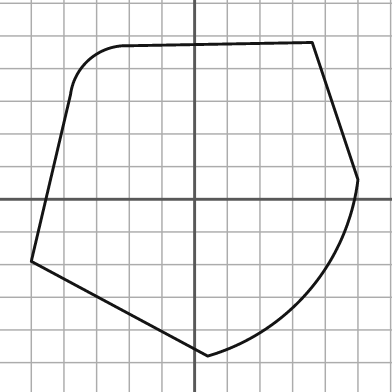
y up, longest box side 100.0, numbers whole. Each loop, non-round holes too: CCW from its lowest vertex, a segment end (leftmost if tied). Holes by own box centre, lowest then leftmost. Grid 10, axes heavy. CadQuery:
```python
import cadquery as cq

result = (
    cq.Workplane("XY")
    .moveTo(4.0, -48.0)
    .threePointArc((35.0, -28.0), (50.0, 6.0))
    .lineTo(36.0, 48.0)
    .lineTo(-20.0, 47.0)
    .threePointArc((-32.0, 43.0), (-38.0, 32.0))
    .lineTo(-50.0, -19.0)
    .close()
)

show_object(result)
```